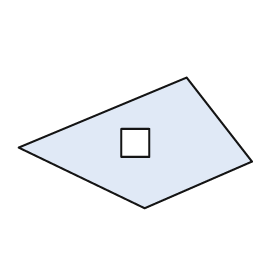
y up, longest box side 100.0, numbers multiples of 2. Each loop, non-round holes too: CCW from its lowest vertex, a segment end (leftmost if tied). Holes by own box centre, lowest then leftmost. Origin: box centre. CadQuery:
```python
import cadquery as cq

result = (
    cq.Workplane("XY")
    .moveTo(4.0, -28.0)
    .lineTo(50.0, -8.0)
    .lineTo(22.0, 28.0)
    .lineTo(-50.0, -2.0)
    .close()
    .moveTo(-6.0, -6.0)
    .lineTo(6.0, -6.0)
    .lineTo(6.0, 6.0)
    .lineTo(-6.0, 6.0)
    .close()
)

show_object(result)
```